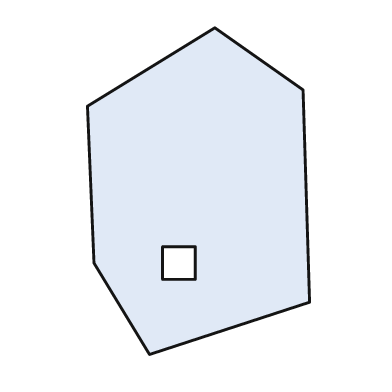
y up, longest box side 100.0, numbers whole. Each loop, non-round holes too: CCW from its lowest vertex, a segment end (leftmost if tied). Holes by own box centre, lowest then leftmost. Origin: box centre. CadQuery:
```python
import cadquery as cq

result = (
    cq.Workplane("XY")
    .moveTo(-15.0, -50.0)
    .lineTo(34.0, -34.0)
    .lineTo(32.0, 31.0)
    .lineTo(5.0, 50.0)
    .lineTo(-34.0, 26.0)
    .lineTo(-32.0, -22.0)
    .close()
    .moveTo(-11.0, -27.0)
    .lineTo(-1.0, -27.0)
    .lineTo(-1.0, -17.0)
    .lineTo(-11.0, -17.0)
    .close()
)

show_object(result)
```